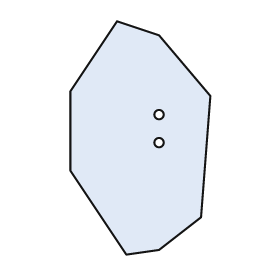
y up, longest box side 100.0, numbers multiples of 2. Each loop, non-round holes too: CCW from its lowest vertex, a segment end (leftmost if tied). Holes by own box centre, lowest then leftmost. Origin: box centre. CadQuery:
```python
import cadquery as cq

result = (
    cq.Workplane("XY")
    .moveTo(-6.0, -50.0)
    .lineTo(8.0, -48.0)
    .lineTo(26.0, -34.0)
    .lineTo(30.0, 18.0)
    .lineTo(8.0, 44.0)
    .lineTo(-10.0, 50.0)
    .lineTo(-30.0, 20.0)
    .lineTo(-30.0, -14.0)
    .close()
    .moveTo(8.0, -2.0)
    .circle(2.0)
    .moveTo(8.0, 10.0)
    .circle(2.0)
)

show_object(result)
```